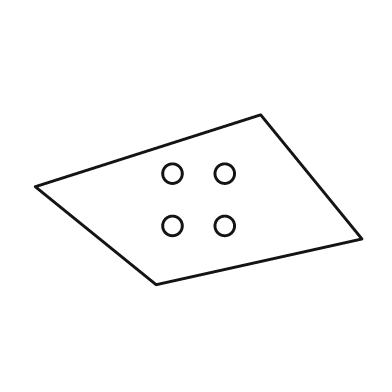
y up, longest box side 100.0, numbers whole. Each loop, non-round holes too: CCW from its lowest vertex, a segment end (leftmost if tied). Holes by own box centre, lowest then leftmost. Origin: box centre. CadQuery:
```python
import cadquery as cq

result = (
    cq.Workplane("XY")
    .moveTo(-13.0, -26.0)
    .lineTo(50.0, -12.0)
    .lineTo(19.0, 26.0)
    .lineTo(-50.0, 4.0)
    .close()
    .moveTo(-8.0, -8.0)
    .circle(3.0)
    .moveTo(8.0, -8.0)
    .circle(3.0)
    .moveTo(-8.0, 8.0)
    .circle(3.0)
    .moveTo(8.0, 8.0)
    .circle(3.0)
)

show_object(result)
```